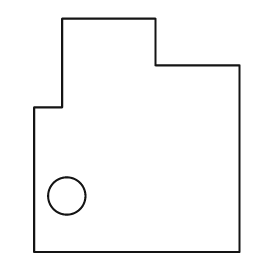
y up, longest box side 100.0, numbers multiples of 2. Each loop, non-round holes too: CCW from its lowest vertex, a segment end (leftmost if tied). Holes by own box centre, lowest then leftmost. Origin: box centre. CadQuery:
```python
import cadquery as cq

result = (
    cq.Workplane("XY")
    .moveTo(-44.0, -50.0)
    .lineTo(44.0, -50.0)
    .lineTo(44.0, 30.0)
    .lineTo(8.0, 30.0)
    .lineTo(8.0, 50.0)
    .lineTo(-32.0, 50.0)
    .lineTo(-32.0, 12.0)
    .lineTo(-44.0, 12.0)
    .close()
    .moveTo(-30.0, -26.0)
    .circle(8.0)
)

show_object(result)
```